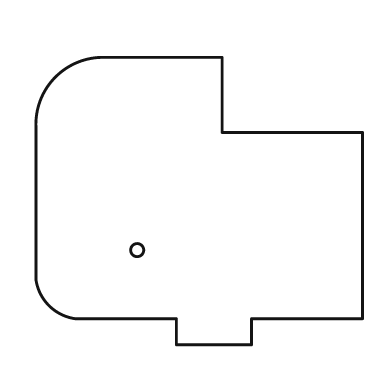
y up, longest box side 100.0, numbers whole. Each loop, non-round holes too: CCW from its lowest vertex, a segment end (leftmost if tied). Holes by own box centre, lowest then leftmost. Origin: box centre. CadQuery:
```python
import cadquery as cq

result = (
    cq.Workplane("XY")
    .moveTo(-7.0, -44.0)
    .lineTo(16.0, -44.0)
    .lineTo(16.0, -36.0)
    .lineTo(50.0, -36.0)
    .lineTo(50.0, 21.0)
    .lineTo(7.0, 21.0)
    .lineTo(7.0, 44.0)
    .lineTo(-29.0, 44.0)
    .threePointArc((-44.0, 38.0), (-50.0, 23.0))
    .lineTo(-50.0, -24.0)
    .threePointArc((-46.0, -32.0), (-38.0, -36.0))
    .lineTo(-7.0, -36.0)
    .close()
    .moveTo(-19.0, -15.0)
    .circle(2.0)
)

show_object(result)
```